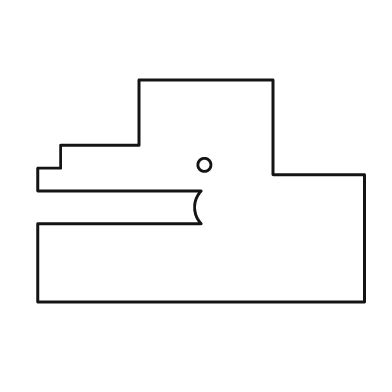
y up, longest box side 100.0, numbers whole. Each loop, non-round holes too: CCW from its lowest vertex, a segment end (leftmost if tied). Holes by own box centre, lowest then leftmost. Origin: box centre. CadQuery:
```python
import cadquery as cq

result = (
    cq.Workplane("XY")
    .moveTo(-50.0, -34.0)
    .lineTo(50.0, -34.0)
    .lineTo(50.0, 5.0)
    .lineTo(22.0, 5.0)
    .lineTo(22.0, 34.0)
    .lineTo(-19.0, 34.0)
    .lineTo(-19.0, 14.0)
    .lineTo(-43.0, 14.0)
    .lineTo(-43.0, 7.0)
    .lineTo(-50.0, 7.0)
    .lineTo(-50.0, 0.0)
    .lineTo(0.0, 0.0)
    .threePointArc((-2.0, -5.0), (0.0, -10.0))
    .lineTo(-50.0, -10.0)
    .close()
    .moveTo(1.0, 8.0)
    .circle(2.0)
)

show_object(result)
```